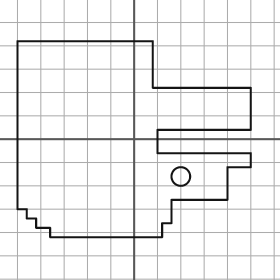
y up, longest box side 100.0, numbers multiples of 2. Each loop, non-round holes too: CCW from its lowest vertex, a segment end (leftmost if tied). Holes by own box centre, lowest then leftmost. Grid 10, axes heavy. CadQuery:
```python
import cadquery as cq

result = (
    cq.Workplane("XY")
    .moveTo(-36.0, -42.0)
    .lineTo(12.0, -42.0)
    .lineTo(12.0, -36.0)
    .lineTo(16.0, -36.0)
    .lineTo(16.0, -26.0)
    .lineTo(40.0, -26.0)
    .lineTo(40.0, -12.0)
    .lineTo(50.0, -12.0)
    .lineTo(50.0, -6.0)
    .lineTo(10.0, -6.0)
    .lineTo(10.0, 4.0)
    .lineTo(50.0, 4.0)
    .lineTo(50.0, 22.0)
    .lineTo(8.0, 22.0)
    .lineTo(8.0, 42.0)
    .lineTo(-50.0, 42.0)
    .lineTo(-50.0, -30.0)
    .lineTo(-46.0, -30.0)
    .lineTo(-46.0, -34.0)
    .lineTo(-42.0, -34.0)
    .lineTo(-42.0, -38.0)
    .lineTo(-36.0, -38.0)
    .close()
    .moveTo(20.0, -16.0)
    .circle(4.0)
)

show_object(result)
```